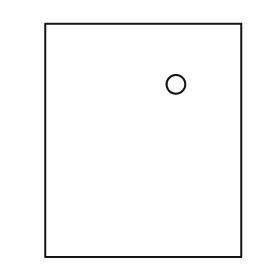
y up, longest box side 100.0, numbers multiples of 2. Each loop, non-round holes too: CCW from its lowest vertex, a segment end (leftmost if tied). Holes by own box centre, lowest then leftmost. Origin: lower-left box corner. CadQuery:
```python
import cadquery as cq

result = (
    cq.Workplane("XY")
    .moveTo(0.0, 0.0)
    .lineTo(84.0, 0.0)
    .lineTo(84.0, 100.0)
    .lineTo(0.0, 100.0)
    .close()
    .moveTo(56.0, 74.0)
    .circle(4.0)
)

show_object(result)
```